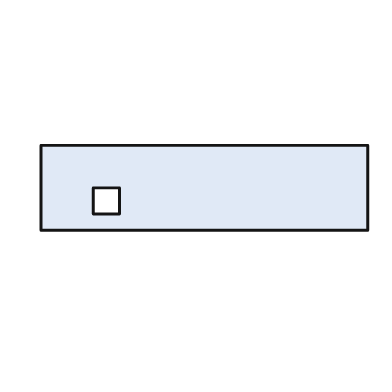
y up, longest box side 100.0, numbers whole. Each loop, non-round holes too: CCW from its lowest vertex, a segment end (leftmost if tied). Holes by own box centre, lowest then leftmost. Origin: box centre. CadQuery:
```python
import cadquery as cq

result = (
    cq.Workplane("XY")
    .moveTo(-50.0, -13.0)
    .lineTo(50.0, -13.0)
    .lineTo(50.0, 13.0)
    .lineTo(-50.0, 13.0)
    .close()
    .moveTo(-34.0, -8.0)
    .lineTo(-26.0, -8.0)
    .lineTo(-26.0, 0.0)
    .lineTo(-34.0, 0.0)
    .close()
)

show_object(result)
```